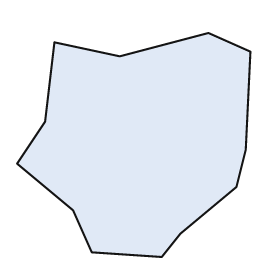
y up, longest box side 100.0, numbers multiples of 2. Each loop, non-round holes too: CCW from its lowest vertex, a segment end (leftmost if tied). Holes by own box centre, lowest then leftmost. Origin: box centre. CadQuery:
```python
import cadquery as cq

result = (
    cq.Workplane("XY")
    .moveTo(12.0, -48.0)
    .lineTo(20.0, -38.0)
    .lineTo(44.0, -18.0)
    .lineTo(48.0, -2.0)
    .lineTo(50.0, 40.0)
    .lineTo(32.0, 48.0)
    .lineTo(-6.0, 38.0)
    .lineTo(-34.0, 44.0)
    .lineTo(-38.0, 10.0)
    .lineTo(-50.0, -8.0)
    .lineTo(-26.0, -28.0)
    .lineTo(-18.0, -46.0)
    .close()
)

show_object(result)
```